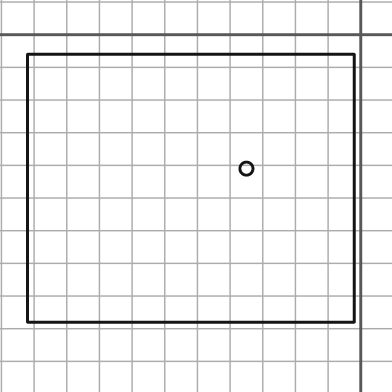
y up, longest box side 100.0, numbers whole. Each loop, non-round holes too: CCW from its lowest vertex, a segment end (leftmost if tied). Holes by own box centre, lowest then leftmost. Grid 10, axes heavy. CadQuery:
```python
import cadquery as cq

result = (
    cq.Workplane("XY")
    .moveTo(-102.0, -88.0)
    .lineTo(-2.0, -88.0)
    .lineTo(-2.0, -6.0)
    .lineTo(-102.0, -6.0)
    .close()
    .moveTo(-35.0, -41.0)
    .circle(2.0)
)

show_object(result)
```